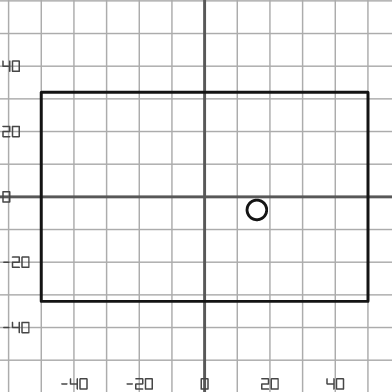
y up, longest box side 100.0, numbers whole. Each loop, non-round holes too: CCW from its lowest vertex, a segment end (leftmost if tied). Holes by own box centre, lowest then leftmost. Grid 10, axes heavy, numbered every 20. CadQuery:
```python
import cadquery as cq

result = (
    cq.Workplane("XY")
    .moveTo(-50.0, -32.0)
    .lineTo(50.0, -32.0)
    .lineTo(50.0, 32.0)
    .lineTo(-50.0, 32.0)
    .close()
    .moveTo(16.0, -4.0)
    .circle(3.0)
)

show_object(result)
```